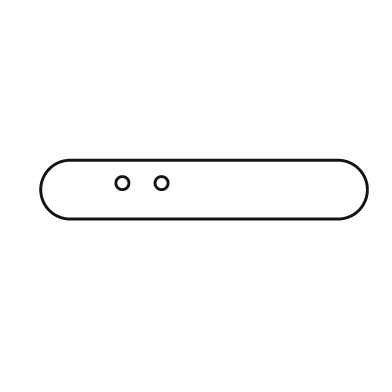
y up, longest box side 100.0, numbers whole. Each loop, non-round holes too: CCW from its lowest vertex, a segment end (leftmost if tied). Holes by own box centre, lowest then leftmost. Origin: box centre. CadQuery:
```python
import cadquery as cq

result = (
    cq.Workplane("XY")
    .moveTo(-41.0, -9.0)
    .lineTo(41.0, -9.0)
    .threePointArc((50.0, 0.0), (41.0, 9.0))
    .lineTo(-41.0, 9.0)
    .threePointArc((-50.0, 0.0), (-41.0, -9.0))
    .close()
    .moveTo(-25.0, 2.0)
    .circle(2.0)
    .moveTo(-13.0, 2.0)
    .circle(2.0)
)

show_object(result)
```